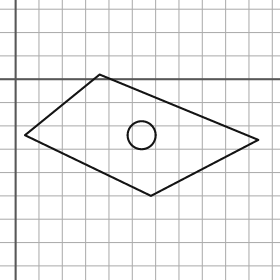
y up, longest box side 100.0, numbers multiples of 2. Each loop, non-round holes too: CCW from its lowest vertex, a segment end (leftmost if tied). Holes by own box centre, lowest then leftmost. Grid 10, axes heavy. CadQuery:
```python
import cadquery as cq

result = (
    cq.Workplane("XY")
    .moveTo(58.0, -50.0)
    .lineTo(104.0, -26.0)
    .lineTo(36.0, 2.0)
    .lineTo(4.0, -24.0)
    .close()
    .moveTo(54.0, -24.0)
    .circle(6.0)
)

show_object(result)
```